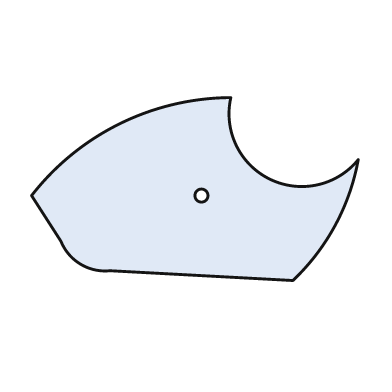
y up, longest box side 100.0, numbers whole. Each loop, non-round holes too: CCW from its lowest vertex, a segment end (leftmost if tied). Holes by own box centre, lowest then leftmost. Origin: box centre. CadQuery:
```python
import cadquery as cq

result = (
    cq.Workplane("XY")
    .moveTo(30.0, -28.0)
    .threePointArc((43.0, -11.0), (50.0, 9.0))
    .threePointArc((23.0, 3.0), (11.0, 28.0))
    .threePointArc((-23.0, 20.0), (-50.0, -2.0))
    .lineTo(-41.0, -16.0)
    .threePointArc((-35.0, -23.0), (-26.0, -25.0))
    .close()
    .moveTo(2.0, -2.0)
    .circle(2.0)
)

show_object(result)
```